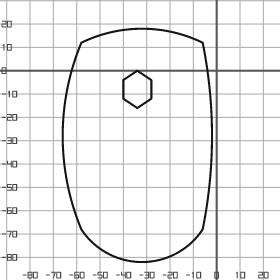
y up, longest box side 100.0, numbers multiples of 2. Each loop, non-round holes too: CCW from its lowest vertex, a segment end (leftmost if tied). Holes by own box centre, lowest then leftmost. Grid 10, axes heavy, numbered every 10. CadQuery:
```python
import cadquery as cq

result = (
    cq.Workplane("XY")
    .moveTo(-58.0, -68.0)
    .threePointArc((-32.0, -82.0), (-6.0, -68.0))
    .threePointArc((-2.0, -28.0), (-6.0, 12.0))
    .threePointArc((-32.0, 18.0), (-58.0, 12.0))
    .threePointArc((-66.0, -28.0), (-58.0, -68.0))
    .close()
    .moveTo(-34.0, -16.0)
    .lineTo(-28.0, -12.0)
    .lineTo(-28.0, -4.0)
    .lineTo(-34.0, 0.0)
    .lineTo(-40.0, -4.0)
    .lineTo(-40.0, -12.0)
    .close()
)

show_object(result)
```